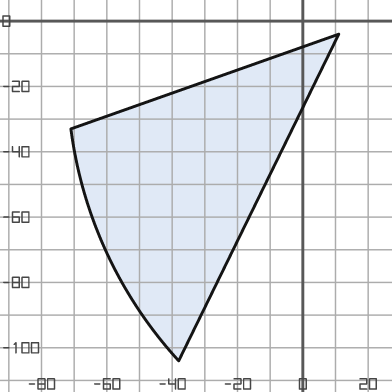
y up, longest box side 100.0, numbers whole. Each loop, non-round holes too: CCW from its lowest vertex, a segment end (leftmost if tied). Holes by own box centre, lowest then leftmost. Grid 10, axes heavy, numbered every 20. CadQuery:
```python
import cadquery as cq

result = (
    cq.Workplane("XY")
    .moveTo(-38.0, -104.0)
    .lineTo(11.0, -4.0)
    .lineTo(-71.0, -33.0)
    .threePointArc((-60.0, -71.0), (-38.0, -104.0))
    .close()
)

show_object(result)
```